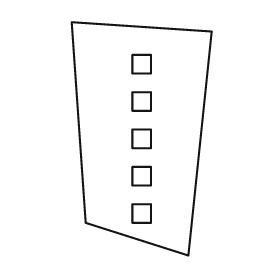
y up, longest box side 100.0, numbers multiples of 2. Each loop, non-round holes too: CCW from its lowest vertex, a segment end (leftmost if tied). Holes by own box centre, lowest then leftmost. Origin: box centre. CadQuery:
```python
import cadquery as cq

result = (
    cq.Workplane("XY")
    .moveTo(20.0, -50.0)
    .lineTo(30.0, 46.0)
    .lineTo(-30.0, 50.0)
    .lineTo(-24.0, -36.0)
    .close()
    .moveTo(-4.0, -36.0)
    .lineTo(4.0, -36.0)
    .lineTo(4.0, -28.0)
    .lineTo(-4.0, -28.0)
    .close()
    .moveTo(-4.0, -20.0)
    .lineTo(4.0, -20.0)
    .lineTo(4.0, -12.0)
    .lineTo(-4.0, -12.0)
    .close()
    .moveTo(-4.0, -4.0)
    .lineTo(4.0, -4.0)
    .lineTo(4.0, 4.0)
    .lineTo(-4.0, 4.0)
    .close()
    .moveTo(-4.0, 12.0)
    .lineTo(4.0, 12.0)
    .lineTo(4.0, 20.0)
    .lineTo(-4.0, 20.0)
    .close()
    .moveTo(-4.0, 28.0)
    .lineTo(4.0, 28.0)
    .lineTo(4.0, 36.0)
    .lineTo(-4.0, 36.0)
    .close()
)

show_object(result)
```